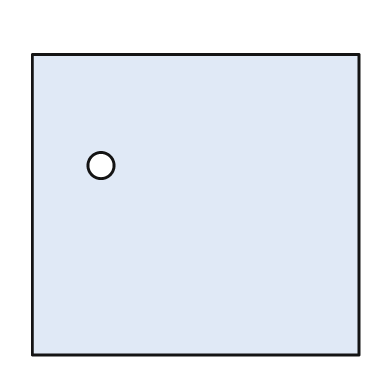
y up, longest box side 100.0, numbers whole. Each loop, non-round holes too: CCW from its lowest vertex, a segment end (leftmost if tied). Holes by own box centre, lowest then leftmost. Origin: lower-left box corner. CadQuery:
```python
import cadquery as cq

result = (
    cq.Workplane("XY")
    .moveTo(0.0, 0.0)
    .lineTo(100.0, 0.0)
    .lineTo(100.0, 92.0)
    .lineTo(0.0, 92.0)
    .close()
    .moveTo(21.0, 58.0)
    .circle(4.0)
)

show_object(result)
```